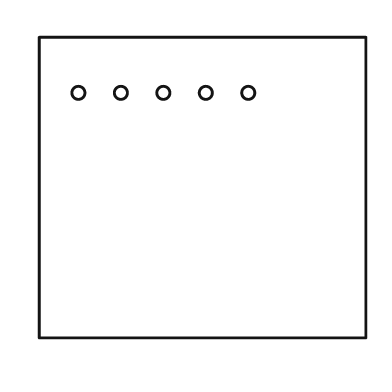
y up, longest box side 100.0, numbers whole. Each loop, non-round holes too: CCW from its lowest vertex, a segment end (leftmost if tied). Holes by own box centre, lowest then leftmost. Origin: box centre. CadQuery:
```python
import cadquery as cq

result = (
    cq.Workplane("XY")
    .moveTo(-50.0, -46.0)
    .lineTo(50.0, -46.0)
    .lineTo(50.0, 46.0)
    .lineTo(-50.0, 46.0)
    .close()
    .moveTo(-38.0, 29.0)
    .circle(2.0)
    .moveTo(-25.0, 29.0)
    .circle(2.0)
    .moveTo(-12.0, 29.0)
    .circle(2.0)
    .moveTo(1.0, 29.0)
    .circle(2.0)
    .moveTo(14.0, 29.0)
    .circle(2.0)
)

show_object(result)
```